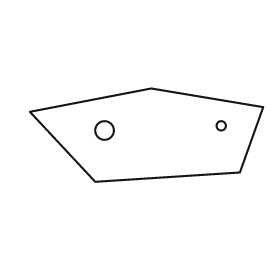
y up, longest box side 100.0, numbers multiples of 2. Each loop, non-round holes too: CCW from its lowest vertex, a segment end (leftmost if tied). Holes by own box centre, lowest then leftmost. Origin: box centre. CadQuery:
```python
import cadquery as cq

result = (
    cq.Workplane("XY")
    .moveTo(-22.0, -20.0)
    .lineTo(40.0, -16.0)
    .lineTo(50.0, 12.0)
    .lineTo(2.0, 20.0)
    .lineTo(-50.0, 10.0)
    .close()
    .moveTo(-18.0, 2.0)
    .circle(4.0)
    .moveTo(32.0, 4.0)
    .circle(2.0)
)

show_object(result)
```